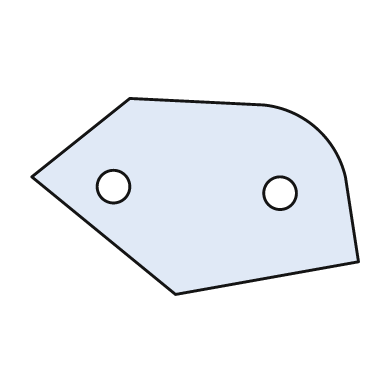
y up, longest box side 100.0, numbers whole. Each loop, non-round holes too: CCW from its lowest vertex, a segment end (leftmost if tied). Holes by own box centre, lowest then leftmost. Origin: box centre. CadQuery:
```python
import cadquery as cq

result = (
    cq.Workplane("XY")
    .moveTo(-6.0, -30.0)
    .lineTo(50.0, -20.0)
    .lineTo(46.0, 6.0)
    .threePointArc((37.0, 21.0), (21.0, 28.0))
    .lineTo(-20.0, 30.0)
    .lineTo(-50.0, 6.0)
    .close()
    .moveTo(26.0, 1.0)
    .circle(5.0)
    .moveTo(-25.0, 3.0)
    .circle(5.0)
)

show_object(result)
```